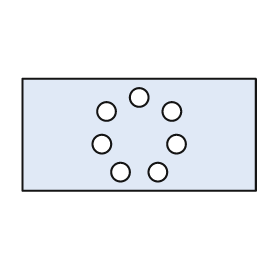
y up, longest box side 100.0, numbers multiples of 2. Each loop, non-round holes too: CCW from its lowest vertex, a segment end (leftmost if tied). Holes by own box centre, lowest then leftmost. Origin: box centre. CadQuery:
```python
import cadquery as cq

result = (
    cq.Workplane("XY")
    .moveTo(-50.0, -24.0)
    .lineTo(50.0, -24.0)
    .lineTo(50.0, 24.0)
    .lineTo(-50.0, 24.0)
    .close()
    .moveTo(-8.0, -16.0)
    .circle(4.0)
    .moveTo(8.0, -16.0)
    .circle(4.0)
    .moveTo(-16.0, -4.0)
    .circle(4.0)
    .moveTo(16.0, -4.0)
    .circle(4.0)
    .moveTo(-14.0, 10.0)
    .circle(4.0)
    .moveTo(14.0, 10.0)
    .circle(4.0)
    .moveTo(0.0, 16.0)
    .circle(4.0)
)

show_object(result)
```